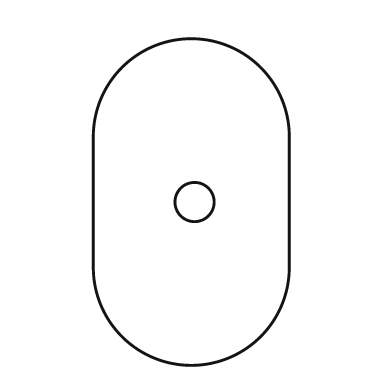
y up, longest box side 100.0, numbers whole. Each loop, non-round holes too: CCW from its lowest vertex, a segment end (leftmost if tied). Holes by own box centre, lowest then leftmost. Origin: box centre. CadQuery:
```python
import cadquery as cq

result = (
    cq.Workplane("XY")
    .moveTo(-30.0, -20.0)
    .threePointArc((0.0, -50.0), (30.0, -20.0))
    .lineTo(30.0, 20.0)
    .threePointArc((0.0, 50.0), (-30.0, 20.0))
    .close()
    .moveTo(1.0, 0.0)
    .circle(6.0)
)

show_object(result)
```